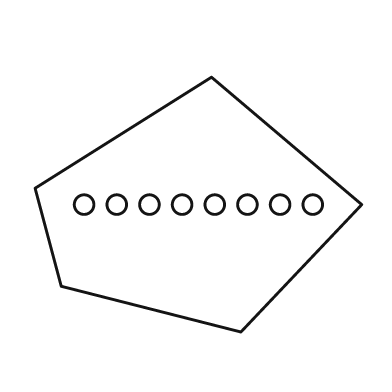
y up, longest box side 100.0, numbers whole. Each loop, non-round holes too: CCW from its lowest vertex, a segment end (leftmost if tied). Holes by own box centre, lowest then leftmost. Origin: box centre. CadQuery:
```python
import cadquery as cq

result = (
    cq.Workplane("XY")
    .moveTo(13.0, -39.0)
    .lineTo(50.0, 0.0)
    .lineTo(4.0, 39.0)
    .lineTo(-50.0, 5.0)
    .lineTo(-42.0, -25.0)
    .close()
    .moveTo(-35.0, 0.0)
    .circle(3.0)
    .moveTo(-25.0, 0.0)
    .circle(3.0)
    .moveTo(-15.0, 0.0)
    .circle(3.0)
    .moveTo(-5.0, 0.0)
    .circle(3.0)
    .moveTo(5.0, 0.0)
    .circle(3.0)
    .moveTo(15.0, 0.0)
    .circle(3.0)
    .moveTo(25.0, 0.0)
    .circle(3.0)
    .moveTo(35.0, 0.0)
    .circle(3.0)
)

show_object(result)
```